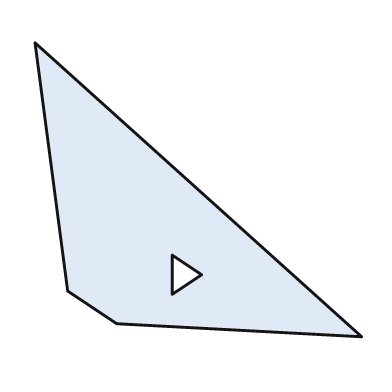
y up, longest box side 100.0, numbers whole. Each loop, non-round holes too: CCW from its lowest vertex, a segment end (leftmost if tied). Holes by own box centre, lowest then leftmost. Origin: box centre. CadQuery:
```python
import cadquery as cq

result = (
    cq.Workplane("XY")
    .moveTo(50.0, -45.0)
    .lineTo(-50.0, 45.0)
    .lineTo(-40.0, -31.0)
    .lineTo(-25.0, -41.0)
    .close()
    .moveTo(-8.0, -32.0)
    .lineTo(1.0, -26.0)
    .lineTo(-8.0, -20.0)
    .close()
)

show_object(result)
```